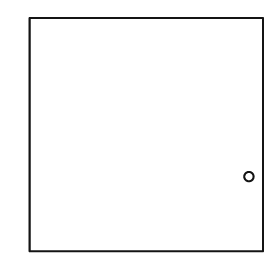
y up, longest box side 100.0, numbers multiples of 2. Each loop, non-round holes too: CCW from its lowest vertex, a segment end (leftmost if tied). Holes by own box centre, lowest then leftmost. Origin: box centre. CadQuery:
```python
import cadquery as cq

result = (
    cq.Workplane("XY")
    .moveTo(-50.0, -50.0)
    .lineTo(50.0, -50.0)
    .lineTo(50.0, 50.0)
    .lineTo(-50.0, 50.0)
    .close()
    .moveTo(44.0, -18.0)
    .circle(2.0)
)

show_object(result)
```